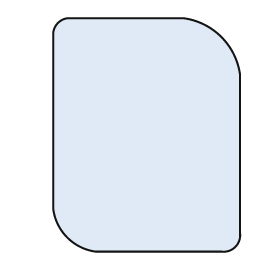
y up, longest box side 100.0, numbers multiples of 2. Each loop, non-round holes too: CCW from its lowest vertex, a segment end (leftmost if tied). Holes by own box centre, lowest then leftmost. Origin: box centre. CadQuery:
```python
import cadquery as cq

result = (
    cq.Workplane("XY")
    .moveTo(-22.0, -50.0)
    .lineTo(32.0, -50.0)
    .threePointArc((38.0, -48.0), (40.0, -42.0))
    .lineTo(40.0, 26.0)
    .threePointArc((32.0, 42.0), (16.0, 50.0))
    .lineTo(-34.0, 50.0)
    .threePointArc((-38.0, 48.0), (-40.0, 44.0))
    .lineTo(-40.0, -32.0)
    .threePointArc((-34.0, -44.0), (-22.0, -50.0))
    .close()
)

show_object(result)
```